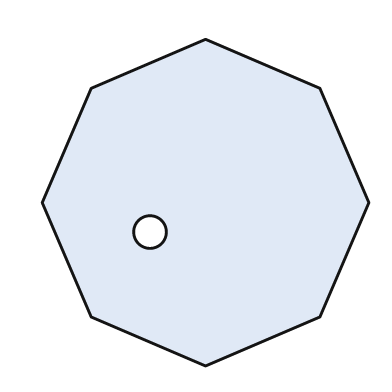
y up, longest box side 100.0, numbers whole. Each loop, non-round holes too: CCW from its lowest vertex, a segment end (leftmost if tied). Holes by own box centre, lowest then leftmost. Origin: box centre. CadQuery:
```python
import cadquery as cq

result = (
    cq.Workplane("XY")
    .moveTo(0.0, -50.0)
    .lineTo(35.0, -35.0)
    .lineTo(50.0, 0.0)
    .lineTo(35.0, 35.0)
    .lineTo(0.0, 50.0)
    .lineTo(-35.0, 35.0)
    .lineTo(-50.0, 0.0)
    .lineTo(-35.0, -35.0)
    .close()
    .moveTo(-17.0, -9.0)
    .circle(5.0)
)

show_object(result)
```